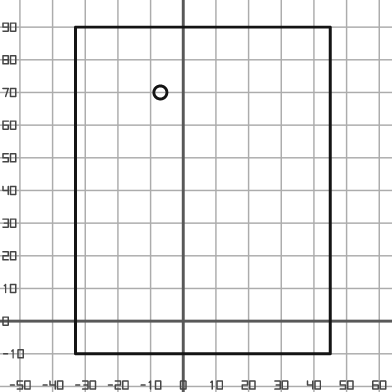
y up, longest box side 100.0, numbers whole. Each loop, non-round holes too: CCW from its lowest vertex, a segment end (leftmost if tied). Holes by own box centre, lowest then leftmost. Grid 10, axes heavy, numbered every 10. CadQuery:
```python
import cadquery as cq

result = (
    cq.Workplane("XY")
    .moveTo(-33.0, -10.0)
    .lineTo(45.0, -10.0)
    .lineTo(45.0, 90.0)
    .lineTo(-33.0, 90.0)
    .close()
    .moveTo(-7.0, 70.0)
    .circle(2.0)
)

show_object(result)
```